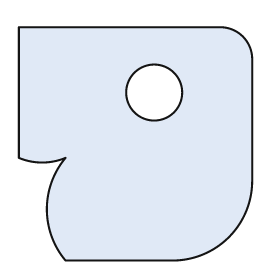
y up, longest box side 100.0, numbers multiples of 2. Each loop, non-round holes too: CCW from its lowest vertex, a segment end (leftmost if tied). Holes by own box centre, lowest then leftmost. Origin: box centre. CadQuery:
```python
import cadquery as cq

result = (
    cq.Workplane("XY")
    .moveTo(-30.0, -50.0)
    .lineTo(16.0, -50.0)
    .threePointArc((40.0, -40.0), (50.0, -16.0))
    .lineTo(50.0, 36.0)
    .threePointArc((46.0, 46.0), (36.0, 50.0))
    .lineTo(-50.0, 50.0)
    .lineTo(-50.0, -6.0)
    .threePointArc((-40.0, -8.0), (-30.0, -6.0))
    .threePointArc((-38.0, -28.0), (-30.0, -50.0))
    .close()
    .moveTo(8.0, 22.0)
    .circle(12.0)
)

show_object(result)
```